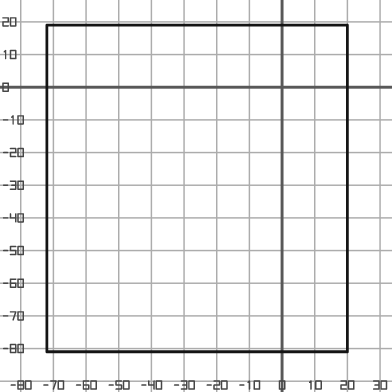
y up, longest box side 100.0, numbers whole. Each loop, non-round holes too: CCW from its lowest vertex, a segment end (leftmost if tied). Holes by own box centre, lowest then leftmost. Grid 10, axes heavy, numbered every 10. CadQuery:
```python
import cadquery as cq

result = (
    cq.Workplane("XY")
    .moveTo(-72.0, -81.0)
    .lineTo(20.0, -81.0)
    .lineTo(20.0, 19.0)
    .lineTo(-72.0, 19.0)
    .close()
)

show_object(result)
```